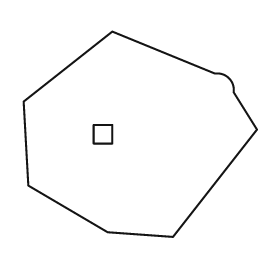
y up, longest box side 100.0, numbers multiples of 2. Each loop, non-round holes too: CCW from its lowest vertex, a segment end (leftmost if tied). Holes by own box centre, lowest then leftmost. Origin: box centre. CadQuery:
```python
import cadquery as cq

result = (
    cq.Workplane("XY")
    .moveTo(14.0, -44.0)
    .lineTo(50.0, 2.0)
    .lineTo(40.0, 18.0)
    .threePointArc((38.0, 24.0), (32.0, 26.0))
    .lineTo(-12.0, 44.0)
    .lineTo(-50.0, 14.0)
    .lineTo(-48.0, -22.0)
    .lineTo(-14.0, -42.0)
    .close()
    .moveTo(-20.0, -4.0)
    .lineTo(-12.0, -4.0)
    .lineTo(-12.0, 4.0)
    .lineTo(-20.0, 4.0)
    .close()
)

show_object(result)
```